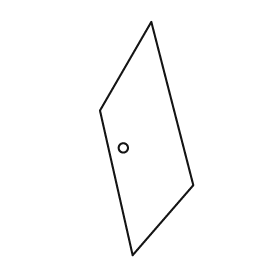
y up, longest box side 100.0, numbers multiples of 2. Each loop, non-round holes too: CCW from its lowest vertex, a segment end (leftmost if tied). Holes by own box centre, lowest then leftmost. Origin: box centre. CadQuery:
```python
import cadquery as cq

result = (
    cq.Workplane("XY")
    .moveTo(-6.0, -50.0)
    .lineTo(20.0, -20.0)
    .lineTo(2.0, 50.0)
    .lineTo(-20.0, 12.0)
    .close()
    .moveTo(-10.0, -4.0)
    .circle(2.0)
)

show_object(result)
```